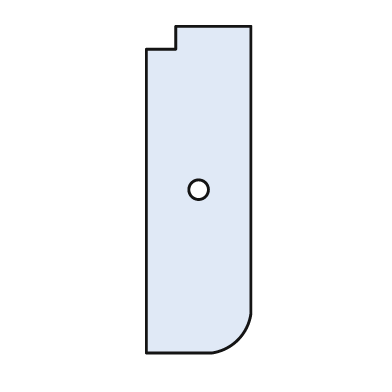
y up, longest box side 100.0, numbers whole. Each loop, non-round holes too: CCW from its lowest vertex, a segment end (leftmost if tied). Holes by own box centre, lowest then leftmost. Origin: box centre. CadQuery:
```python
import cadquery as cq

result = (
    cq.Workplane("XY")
    .moveTo(-16.0, -50.0)
    .lineTo(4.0, -50.0)
    .threePointArc((12.0, -46.0), (16.0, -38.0))
    .lineTo(16.0, 50.0)
    .lineTo(-7.0, 50.0)
    .lineTo(-7.0, 43.0)
    .lineTo(-16.0, 43.0)
    .close()
    .moveTo(0.0, 0.0)
    .circle(3.0)
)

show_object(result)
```